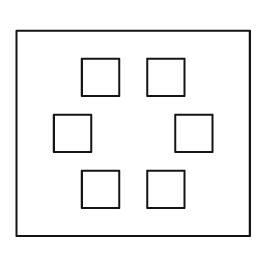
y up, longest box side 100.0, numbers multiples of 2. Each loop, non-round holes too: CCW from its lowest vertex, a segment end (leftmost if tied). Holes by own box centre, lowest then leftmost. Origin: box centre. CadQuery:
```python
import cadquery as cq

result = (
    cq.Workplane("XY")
    .moveTo(-50.0, -44.0)
    .lineTo(50.0, -44.0)
    .lineTo(50.0, 44.0)
    .lineTo(-50.0, 44.0)
    .close()
    .moveTo(-22.0, -32.0)
    .lineTo(-6.0, -32.0)
    .lineTo(-6.0, -16.0)
    .lineTo(-22.0, -16.0)
    .close()
    .moveTo(6.0, -32.0)
    .lineTo(22.0, -32.0)
    .lineTo(22.0, -16.0)
    .lineTo(6.0, -16.0)
    .close()
    .moveTo(-34.0, -8.0)
    .lineTo(-18.0, -8.0)
    .lineTo(-18.0, 8.0)
    .lineTo(-34.0, 8.0)
    .close()
    .moveTo(18.0, -8.0)
    .lineTo(34.0, -8.0)
    .lineTo(34.0, 8.0)
    .lineTo(18.0, 8.0)
    .close()
    .moveTo(-22.0, 16.0)
    .lineTo(-6.0, 16.0)
    .lineTo(-6.0, 32.0)
    .lineTo(-22.0, 32.0)
    .close()
    .moveTo(6.0, 16.0)
    .lineTo(22.0, 16.0)
    .lineTo(22.0, 32.0)
    .lineTo(6.0, 32.0)
    .close()
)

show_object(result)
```